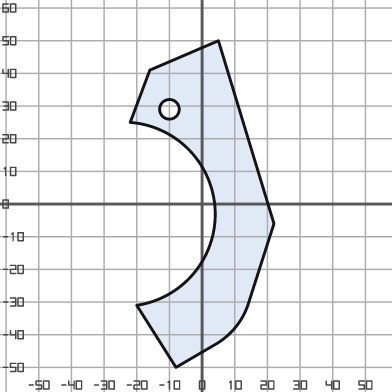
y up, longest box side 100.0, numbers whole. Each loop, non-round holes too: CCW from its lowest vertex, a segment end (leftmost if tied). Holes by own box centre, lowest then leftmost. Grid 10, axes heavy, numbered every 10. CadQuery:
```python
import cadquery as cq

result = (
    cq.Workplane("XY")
    .moveTo(-8.0, -50.0)
    .lineTo(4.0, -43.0)
    .threePointArc((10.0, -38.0), (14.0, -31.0))
    .lineTo(22.0, -6.0)
    .lineTo(5.0, 50.0)
    .lineTo(-16.0, 41.0)
    .lineTo(-22.0, 25.0)
    .threePointArc((4.0, -2.0), (-20.0, -31.0))
    .close()
    .moveTo(-10.0, 29.0)
    .circle(3.0)
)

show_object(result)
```